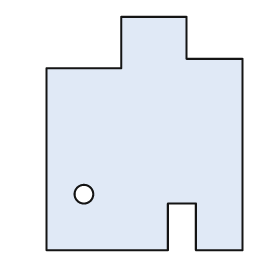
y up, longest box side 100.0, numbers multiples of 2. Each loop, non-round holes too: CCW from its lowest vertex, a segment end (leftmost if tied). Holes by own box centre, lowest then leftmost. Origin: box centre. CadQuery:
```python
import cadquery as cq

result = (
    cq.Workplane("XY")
    .moveTo(-42.0, -50.0)
    .lineTo(10.0, -50.0)
    .lineTo(10.0, -30.0)
    .lineTo(22.0, -30.0)
    .lineTo(22.0, -50.0)
    .lineTo(42.0, -50.0)
    .lineTo(42.0, 32.0)
    .lineTo(18.0, 32.0)
    .lineTo(18.0, 50.0)
    .lineTo(-10.0, 50.0)
    .lineTo(-10.0, 28.0)
    .lineTo(-42.0, 28.0)
    .close()
    .moveTo(-26.0, -26.0)
    .circle(4.0)
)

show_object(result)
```